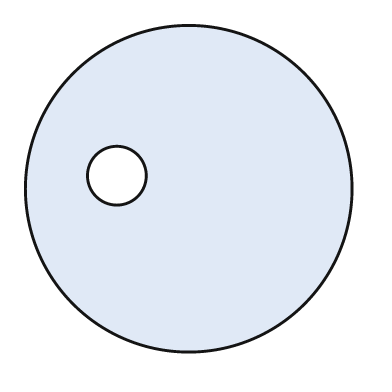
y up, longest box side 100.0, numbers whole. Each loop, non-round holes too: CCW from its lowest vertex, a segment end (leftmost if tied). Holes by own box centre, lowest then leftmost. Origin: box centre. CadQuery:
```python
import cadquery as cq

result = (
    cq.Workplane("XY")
    .moveTo(0.0, 0.0)
    .circle(50.0)
    .moveTo(-22.0, 4.0)
    .circle(9.0)
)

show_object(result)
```